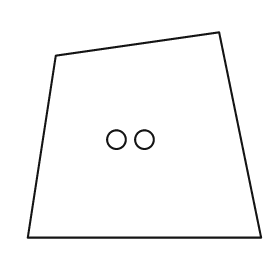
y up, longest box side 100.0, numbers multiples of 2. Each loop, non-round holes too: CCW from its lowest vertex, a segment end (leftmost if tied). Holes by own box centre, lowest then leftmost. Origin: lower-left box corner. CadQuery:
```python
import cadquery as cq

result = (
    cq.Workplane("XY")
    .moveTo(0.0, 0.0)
    .lineTo(100.0, 0.0)
    .lineTo(82.0, 88.0)
    .lineTo(12.0, 78.0)
    .close()
    .moveTo(38.0, 42.0)
    .circle(4.0)
    .moveTo(50.0, 42.0)
    .circle(4.0)
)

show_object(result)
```